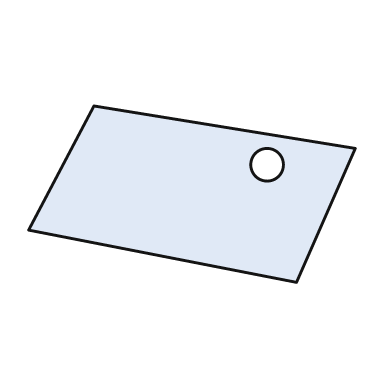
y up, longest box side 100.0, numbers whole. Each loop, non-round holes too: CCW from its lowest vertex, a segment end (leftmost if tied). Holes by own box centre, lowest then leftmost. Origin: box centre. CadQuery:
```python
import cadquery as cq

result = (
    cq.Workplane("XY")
    .moveTo(32.0, -27.0)
    .lineTo(50.0, 14.0)
    .lineTo(-30.0, 27.0)
    .lineTo(-50.0, -11.0)
    .close()
    .moveTo(23.0, 9.0)
    .circle(5.0)
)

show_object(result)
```